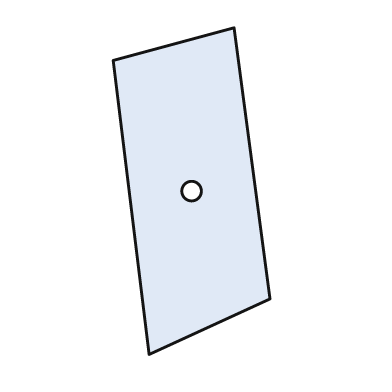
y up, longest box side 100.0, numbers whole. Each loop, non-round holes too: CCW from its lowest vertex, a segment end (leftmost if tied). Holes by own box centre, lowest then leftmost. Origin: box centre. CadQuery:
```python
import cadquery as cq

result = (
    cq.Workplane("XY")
    .moveTo(-13.0, -50.0)
    .lineTo(24.0, -33.0)
    .lineTo(13.0, 50.0)
    .lineTo(-24.0, 40.0)
    .close()
    .moveTo(0.0, 0.0)
    .circle(3.0)
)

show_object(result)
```